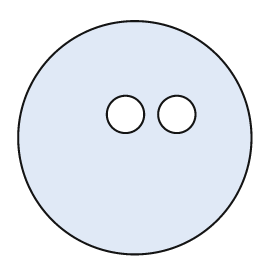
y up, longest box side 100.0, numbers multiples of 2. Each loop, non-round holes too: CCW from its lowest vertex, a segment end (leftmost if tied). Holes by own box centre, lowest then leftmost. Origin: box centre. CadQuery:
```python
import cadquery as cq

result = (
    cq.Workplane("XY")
    .moveTo(0.0, 0.0)
    .circle(50.0)
    .moveTo(-4.0, 10.0)
    .circle(8.0)
    .moveTo(18.0, 10.0)
    .circle(8.0)
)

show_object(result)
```